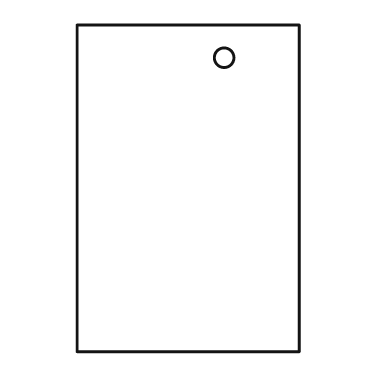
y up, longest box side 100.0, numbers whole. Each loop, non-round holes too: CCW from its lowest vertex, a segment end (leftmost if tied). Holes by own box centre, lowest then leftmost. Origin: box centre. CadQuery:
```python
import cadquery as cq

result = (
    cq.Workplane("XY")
    .moveTo(-34.0, -50.0)
    .lineTo(34.0, -50.0)
    .lineTo(34.0, 50.0)
    .lineTo(-34.0, 50.0)
    .close()
    .moveTo(11.0, 40.0)
    .circle(3.0)
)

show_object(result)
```